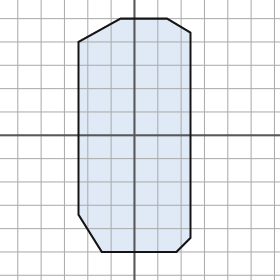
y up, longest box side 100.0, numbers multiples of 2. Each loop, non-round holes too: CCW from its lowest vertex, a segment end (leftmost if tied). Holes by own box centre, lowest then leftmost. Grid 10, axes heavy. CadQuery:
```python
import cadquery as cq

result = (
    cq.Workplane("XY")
    .moveTo(-14.0, -50.0)
    .lineTo(18.0, -50.0)
    .lineTo(24.0, -44.0)
    .lineTo(24.0, 44.0)
    .lineTo(14.0, 50.0)
    .lineTo(-6.0, 50.0)
    .lineTo(-24.0, 40.0)
    .lineTo(-24.0, -34.0)
    .close()
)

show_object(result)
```